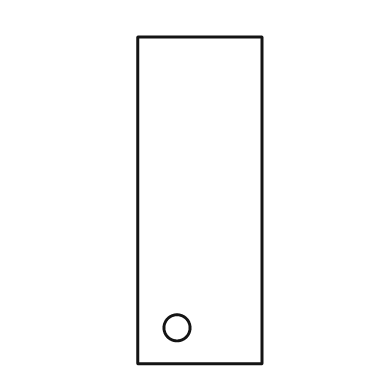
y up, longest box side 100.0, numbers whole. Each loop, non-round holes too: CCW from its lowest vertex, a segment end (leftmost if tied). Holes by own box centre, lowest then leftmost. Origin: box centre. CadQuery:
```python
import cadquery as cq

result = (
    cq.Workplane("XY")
    .moveTo(-19.0, -50.0)
    .lineTo(19.0, -50.0)
    .lineTo(19.0, 50.0)
    .lineTo(-19.0, 50.0)
    .close()
    .moveTo(-7.0, -39.0)
    .circle(4.0)
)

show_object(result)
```